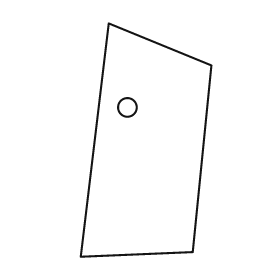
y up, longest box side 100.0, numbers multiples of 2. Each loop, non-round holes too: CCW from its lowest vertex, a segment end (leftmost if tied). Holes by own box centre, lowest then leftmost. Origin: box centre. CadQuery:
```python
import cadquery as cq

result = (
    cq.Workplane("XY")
    .moveTo(-28.0, -50.0)
    .lineTo(20.0, -48.0)
    .lineTo(28.0, 32.0)
    .lineTo(-16.0, 50.0)
    .close()
    .moveTo(-8.0, 14.0)
    .circle(4.0)
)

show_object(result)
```